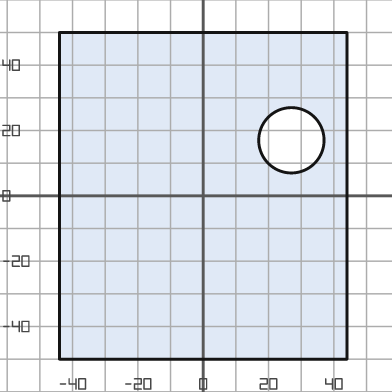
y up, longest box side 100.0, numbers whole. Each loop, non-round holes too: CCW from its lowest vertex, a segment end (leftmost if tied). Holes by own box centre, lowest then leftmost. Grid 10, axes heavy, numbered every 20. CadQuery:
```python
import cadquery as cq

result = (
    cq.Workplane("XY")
    .moveTo(-44.0, -50.0)
    .lineTo(44.0, -50.0)
    .lineTo(44.0, 50.0)
    .lineTo(-44.0, 50.0)
    .close()
    .moveTo(27.0, 17.0)
    .circle(10.0)
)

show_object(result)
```